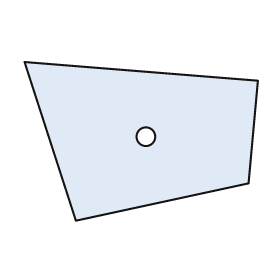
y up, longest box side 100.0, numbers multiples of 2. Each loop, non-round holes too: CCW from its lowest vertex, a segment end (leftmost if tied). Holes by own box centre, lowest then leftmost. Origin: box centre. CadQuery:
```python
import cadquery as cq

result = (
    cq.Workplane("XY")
    .moveTo(-28.0, -34.0)
    .lineTo(46.0, -18.0)
    .lineTo(50.0, 26.0)
    .lineTo(-50.0, 34.0)
    .close()
    .moveTo(2.0, 2.0)
    .circle(4.0)
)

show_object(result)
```